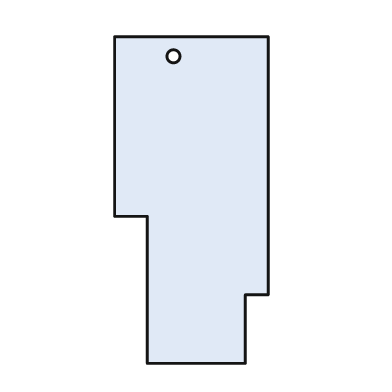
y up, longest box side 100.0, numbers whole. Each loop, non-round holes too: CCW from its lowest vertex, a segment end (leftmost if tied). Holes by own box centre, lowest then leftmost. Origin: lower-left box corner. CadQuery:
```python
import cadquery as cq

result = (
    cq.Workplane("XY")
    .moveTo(10.0, 0.0)
    .lineTo(40.0, 0.0)
    .lineTo(40.0, 21.0)
    .lineTo(47.0, 21.0)
    .lineTo(47.0, 100.0)
    .lineTo(0.0, 100.0)
    .lineTo(0.0, 45.0)
    .lineTo(10.0, 45.0)
    .close()
    .moveTo(18.0, 94.0)
    .circle(2.0)
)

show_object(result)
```